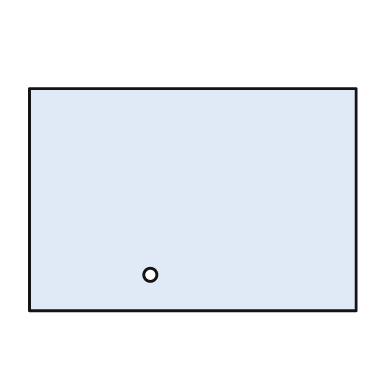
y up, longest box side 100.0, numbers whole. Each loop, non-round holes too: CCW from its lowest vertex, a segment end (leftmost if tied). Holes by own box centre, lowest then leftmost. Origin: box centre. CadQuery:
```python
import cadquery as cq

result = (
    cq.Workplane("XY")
    .moveTo(-50.0, -34.0)
    .lineTo(50.0, -34.0)
    .lineTo(50.0, 34.0)
    .lineTo(-50.0, 34.0)
    .close()
    .moveTo(-13.0, -23.0)
    .circle(2.0)
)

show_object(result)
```